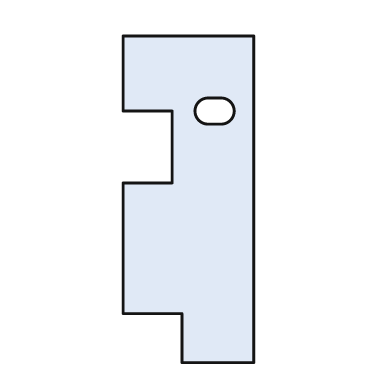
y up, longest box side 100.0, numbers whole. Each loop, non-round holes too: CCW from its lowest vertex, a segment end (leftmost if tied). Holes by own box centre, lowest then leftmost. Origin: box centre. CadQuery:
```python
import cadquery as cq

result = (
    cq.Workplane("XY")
    .moveTo(-2.0, -50.0)
    .lineTo(20.0, -50.0)
    .lineTo(20.0, 50.0)
    .lineTo(-20.0, 50.0)
    .lineTo(-20.0, 27.0)
    .lineTo(-5.0, 27.0)
    .lineTo(-5.0, 5.0)
    .lineTo(-20.0, 5.0)
    .lineTo(-20.0, -35.0)
    .lineTo(-2.0, -35.0)
    .close()
    .moveTo(6.0, 23.0)
    .lineTo(10.0, 23.0)
    .threePointArc((14.0, 27.0), (10.0, 31.0))
    .lineTo(6.0, 31.0)
    .threePointArc((2.0, 27.0), (6.0, 23.0))
    .close()
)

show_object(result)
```